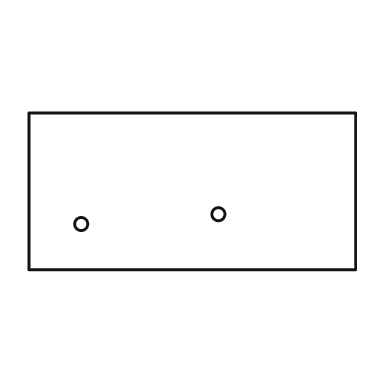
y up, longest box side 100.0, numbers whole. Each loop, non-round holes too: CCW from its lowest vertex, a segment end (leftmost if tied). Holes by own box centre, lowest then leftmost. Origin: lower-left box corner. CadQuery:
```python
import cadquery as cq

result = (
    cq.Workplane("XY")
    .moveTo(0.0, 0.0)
    .lineTo(100.0, 0.0)
    .lineTo(100.0, 48.0)
    .lineTo(0.0, 48.0)
    .close()
    .moveTo(16.0, 14.0)
    .circle(2.0)
    .moveTo(58.0, 17.0)
    .circle(2.0)
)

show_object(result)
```